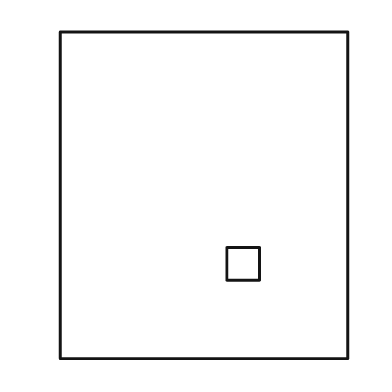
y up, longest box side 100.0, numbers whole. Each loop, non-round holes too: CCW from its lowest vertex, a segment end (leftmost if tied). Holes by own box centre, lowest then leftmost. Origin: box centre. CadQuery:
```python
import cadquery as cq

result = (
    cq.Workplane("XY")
    .moveTo(-44.0, -50.0)
    .lineTo(44.0, -50.0)
    .lineTo(44.0, 50.0)
    .lineTo(-44.0, 50.0)
    .close()
    .moveTo(7.0, -26.0)
    .lineTo(17.0, -26.0)
    .lineTo(17.0, -16.0)
    .lineTo(7.0, -16.0)
    .close()
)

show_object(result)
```